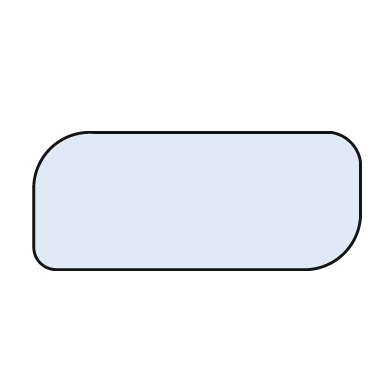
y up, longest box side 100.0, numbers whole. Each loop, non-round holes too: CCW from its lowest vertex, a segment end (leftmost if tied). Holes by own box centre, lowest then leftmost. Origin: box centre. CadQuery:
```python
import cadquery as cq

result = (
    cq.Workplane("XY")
    .moveTo(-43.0, -21.0)
    .lineTo(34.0, -21.0)
    .threePointArc((45.0, -16.0), (50.0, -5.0))
    .lineTo(50.0, 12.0)
    .threePointArc((47.0, 18.0), (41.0, 21.0))
    .lineTo(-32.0, 21.0)
    .threePointArc((-45.0, 16.0), (-50.0, 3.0))
    .lineTo(-50.0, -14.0)
    .threePointArc((-48.0, -19.0), (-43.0, -21.0))
    .close()
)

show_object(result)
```